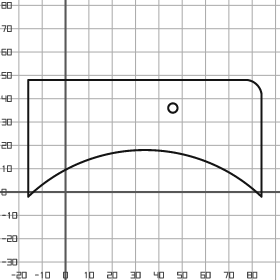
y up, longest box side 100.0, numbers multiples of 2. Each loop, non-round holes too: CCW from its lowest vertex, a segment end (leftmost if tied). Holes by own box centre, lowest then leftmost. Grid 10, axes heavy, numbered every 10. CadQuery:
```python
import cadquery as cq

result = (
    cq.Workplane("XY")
    .moveTo(-16.0, -2.0)
    .threePointArc((34.0, 18.0), (84.0, -2.0))
    .lineTo(84.0, 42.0)
    .threePointArc((82.0, 46.0), (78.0, 48.0))
    .lineTo(-16.0, 48.0)
    .close()
    .moveTo(46.0, 36.0)
    .circle(2.0)
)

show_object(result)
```